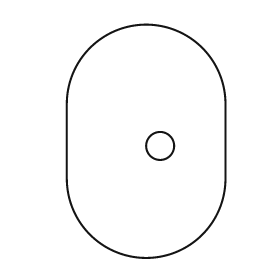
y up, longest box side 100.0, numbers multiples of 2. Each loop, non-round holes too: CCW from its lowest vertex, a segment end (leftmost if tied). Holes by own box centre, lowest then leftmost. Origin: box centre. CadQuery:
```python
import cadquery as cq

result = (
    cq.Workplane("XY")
    .moveTo(-34.0, -16.0)
    .threePointArc((0.0, -50.0), (34.0, -16.0))
    .lineTo(34.0, 16.0)
    .threePointArc((0.0, 50.0), (-34.0, 16.0))
    .close()
    .moveTo(6.0, -2.0)
    .circle(6.0)
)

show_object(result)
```